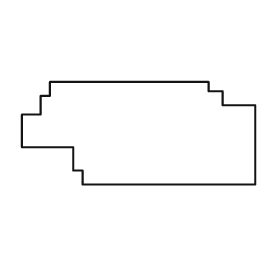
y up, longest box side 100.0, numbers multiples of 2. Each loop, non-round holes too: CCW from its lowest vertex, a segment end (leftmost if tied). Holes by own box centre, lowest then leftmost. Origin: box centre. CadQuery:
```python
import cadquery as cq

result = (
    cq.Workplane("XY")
    .moveTo(-24.0, -22.0)
    .lineTo(50.0, -22.0)
    .lineTo(50.0, 12.0)
    .lineTo(36.0, 12.0)
    .lineTo(36.0, 18.0)
    .lineTo(30.0, 18.0)
    .lineTo(30.0, 22.0)
    .lineTo(-38.0, 22.0)
    .lineTo(-38.0, 16.0)
    .lineTo(-42.0, 16.0)
    .lineTo(-42.0, 8.0)
    .lineTo(-50.0, 8.0)
    .lineTo(-50.0, -6.0)
    .lineTo(-28.0, -6.0)
    .lineTo(-28.0, -16.0)
    .lineTo(-24.0, -16.0)
    .close()
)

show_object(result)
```